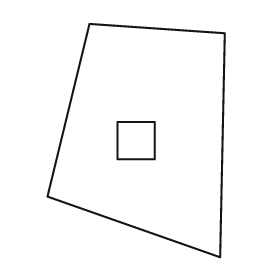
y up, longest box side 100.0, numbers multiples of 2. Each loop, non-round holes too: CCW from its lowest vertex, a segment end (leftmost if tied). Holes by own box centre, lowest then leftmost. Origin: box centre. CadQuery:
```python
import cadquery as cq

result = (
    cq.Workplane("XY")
    .moveTo(36.0, -50.0)
    .lineTo(38.0, 46.0)
    .lineTo(-20.0, 50.0)
    .lineTo(-38.0, -24.0)
    .close()
    .moveTo(-8.0, -8.0)
    .lineTo(8.0, -8.0)
    .lineTo(8.0, 8.0)
    .lineTo(-8.0, 8.0)
    .close()
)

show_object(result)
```